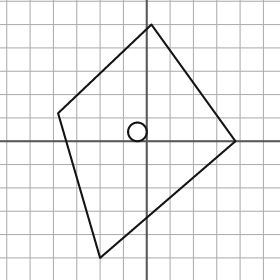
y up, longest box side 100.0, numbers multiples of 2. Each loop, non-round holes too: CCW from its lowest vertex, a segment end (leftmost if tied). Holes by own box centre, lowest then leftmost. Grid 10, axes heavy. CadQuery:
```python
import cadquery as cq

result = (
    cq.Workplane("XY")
    .moveTo(-20.0, -50.0)
    .lineTo(38.0, 0.0)
    .lineTo(2.0, 50.0)
    .lineTo(-38.0, 12.0)
    .close()
    .moveTo(-4.0, 4.0)
    .circle(4.0)
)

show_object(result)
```